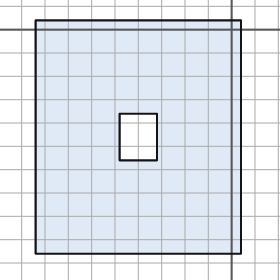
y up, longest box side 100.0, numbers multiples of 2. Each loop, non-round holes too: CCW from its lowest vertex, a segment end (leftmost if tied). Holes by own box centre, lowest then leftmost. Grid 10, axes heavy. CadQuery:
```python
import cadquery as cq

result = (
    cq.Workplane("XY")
    .moveTo(-84.0, -96.0)
    .lineTo(4.0, -96.0)
    .lineTo(4.0, 4.0)
    .lineTo(-84.0, 4.0)
    .close()
    .moveTo(-48.0, -56.0)
    .lineTo(-32.0, -56.0)
    .lineTo(-32.0, -36.0)
    .lineTo(-48.0, -36.0)
    .close()
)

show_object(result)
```